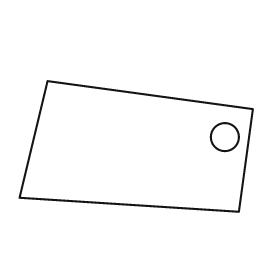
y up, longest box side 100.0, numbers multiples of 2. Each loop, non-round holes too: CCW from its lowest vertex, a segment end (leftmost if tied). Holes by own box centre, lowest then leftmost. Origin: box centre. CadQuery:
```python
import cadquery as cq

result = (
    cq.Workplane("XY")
    .moveTo(44.0, -28.0)
    .lineTo(50.0, 16.0)
    .lineTo(-38.0, 28.0)
    .lineTo(-50.0, -22.0)
    .close()
    .moveTo(38.0, 4.0)
    .circle(6.0)
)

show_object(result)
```